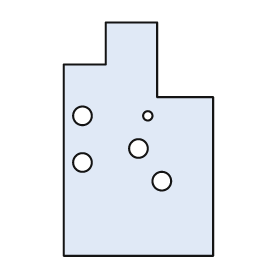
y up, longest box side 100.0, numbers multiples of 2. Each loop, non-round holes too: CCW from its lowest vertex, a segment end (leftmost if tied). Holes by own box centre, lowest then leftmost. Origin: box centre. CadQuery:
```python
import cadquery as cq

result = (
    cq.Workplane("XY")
    .moveTo(-32.0, -50.0)
    .lineTo(32.0, -50.0)
    .lineTo(32.0, 18.0)
    .lineTo(8.0, 18.0)
    .lineTo(8.0, 50.0)
    .lineTo(-14.0, 50.0)
    .lineTo(-14.0, 32.0)
    .lineTo(-32.0, 32.0)
    .close()
    .moveTo(10.0, -18.0)
    .circle(4.0)
    .moveTo(-24.0, -10.0)
    .circle(4.0)
    .moveTo(0.0, -4.0)
    .circle(4.0)
    .moveTo(-24.0, 10.0)
    .circle(4.0)
    .moveTo(4.0, 10.0)
    .circle(2.0)
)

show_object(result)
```